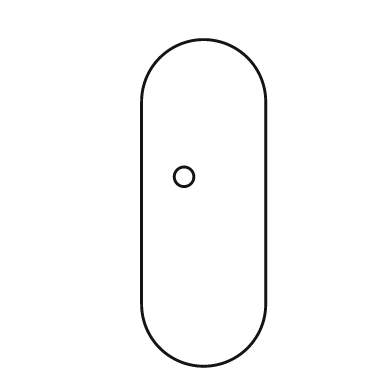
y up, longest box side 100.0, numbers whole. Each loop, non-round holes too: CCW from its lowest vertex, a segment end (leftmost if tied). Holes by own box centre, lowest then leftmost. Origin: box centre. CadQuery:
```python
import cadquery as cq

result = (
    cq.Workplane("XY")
    .moveTo(-19.0, -31.0)
    .threePointArc((0.0, -50.0), (19.0, -31.0))
    .lineTo(19.0, 31.0)
    .threePointArc((0.0, 50.0), (-19.0, 31.0))
    .close()
    .moveTo(-6.0, 8.0)
    .circle(3.0)
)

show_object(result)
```